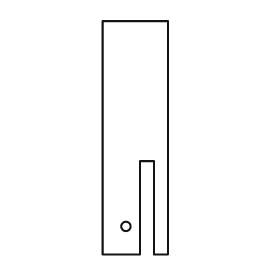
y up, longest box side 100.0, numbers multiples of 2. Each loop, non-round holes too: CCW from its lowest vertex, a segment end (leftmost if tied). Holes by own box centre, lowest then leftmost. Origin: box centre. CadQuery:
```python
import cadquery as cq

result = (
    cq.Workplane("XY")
    .moveTo(-14.0, -50.0)
    .lineTo(2.0, -50.0)
    .lineTo(2.0, -10.0)
    .lineTo(8.0, -10.0)
    .lineTo(8.0, -50.0)
    .lineTo(14.0, -50.0)
    .lineTo(14.0, 50.0)
    .lineTo(-14.0, 50.0)
    .close()
    .moveTo(-4.0, -38.0)
    .circle(2.0)
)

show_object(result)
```